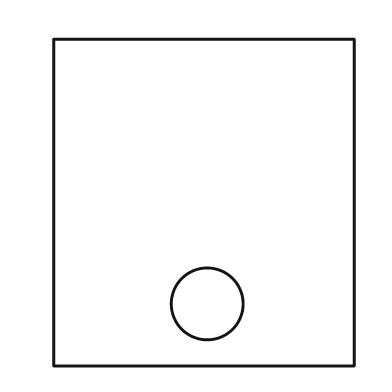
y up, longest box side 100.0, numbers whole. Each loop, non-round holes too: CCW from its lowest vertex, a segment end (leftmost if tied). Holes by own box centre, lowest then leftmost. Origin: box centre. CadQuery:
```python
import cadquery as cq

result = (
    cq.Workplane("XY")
    .moveTo(-46.0, -50.0)
    .lineTo(46.0, -50.0)
    .lineTo(46.0, 50.0)
    .lineTo(-46.0, 50.0)
    .close()
    .moveTo(1.0, -31.0)
    .circle(11.0)
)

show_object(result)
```